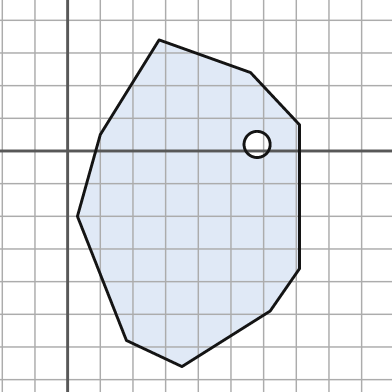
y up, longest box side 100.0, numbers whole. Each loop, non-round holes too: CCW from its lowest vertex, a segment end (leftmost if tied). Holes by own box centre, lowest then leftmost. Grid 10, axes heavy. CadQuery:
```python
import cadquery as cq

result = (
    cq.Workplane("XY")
    .moveTo(35.0, -66.0)
    .lineTo(62.0, -49.0)
    .lineTo(71.0, -36.0)
    .lineTo(71.0, 8.0)
    .lineTo(56.0, 24.0)
    .lineTo(28.0, 34.0)
    .lineTo(10.0, 5.0)
    .lineTo(3.0, -20.0)
    .lineTo(18.0, -58.0)
    .close()
    .moveTo(58.0, 2.0)
    .circle(4.0)
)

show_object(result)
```